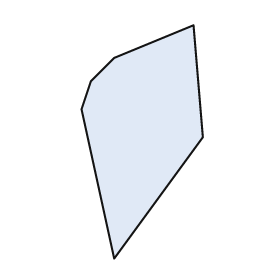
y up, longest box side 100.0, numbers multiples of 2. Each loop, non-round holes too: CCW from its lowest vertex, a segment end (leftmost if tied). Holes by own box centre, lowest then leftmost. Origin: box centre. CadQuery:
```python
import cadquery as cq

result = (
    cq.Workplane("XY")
    .moveTo(-12.0, -50.0)
    .lineTo(26.0, 2.0)
    .lineTo(22.0, 50.0)
    .lineTo(-12.0, 36.0)
    .lineTo(-22.0, 26.0)
    .lineTo(-26.0, 14.0)
    .close()
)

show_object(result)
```